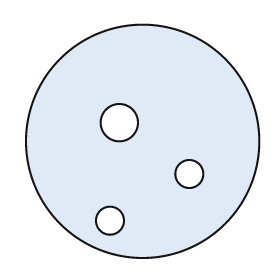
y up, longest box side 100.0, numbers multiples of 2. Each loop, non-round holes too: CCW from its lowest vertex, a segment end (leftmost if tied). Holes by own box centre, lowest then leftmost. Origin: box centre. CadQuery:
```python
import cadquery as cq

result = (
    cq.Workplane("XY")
    .moveTo(0.0, 0.0)
    .circle(50.0)
    .moveTo(-14.0, -34.0)
    .circle(6.0)
    .moveTo(20.0, -14.0)
    .circle(6.0)
    .moveTo(-10.0, 8.0)
    .circle(8.0)
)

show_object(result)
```